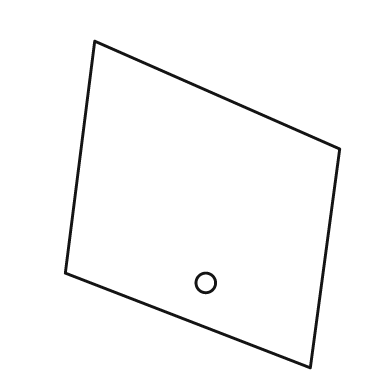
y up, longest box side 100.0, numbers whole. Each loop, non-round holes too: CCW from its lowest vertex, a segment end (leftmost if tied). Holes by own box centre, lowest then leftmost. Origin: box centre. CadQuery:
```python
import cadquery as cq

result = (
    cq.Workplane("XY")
    .moveTo(33.0, -50.0)
    .lineTo(42.0, 17.0)
    .lineTo(-33.0, 50.0)
    .lineTo(-42.0, -21.0)
    .close()
    .moveTo(1.0, -24.0)
    .circle(3.0)
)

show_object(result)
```